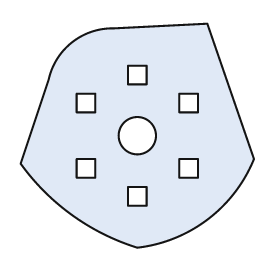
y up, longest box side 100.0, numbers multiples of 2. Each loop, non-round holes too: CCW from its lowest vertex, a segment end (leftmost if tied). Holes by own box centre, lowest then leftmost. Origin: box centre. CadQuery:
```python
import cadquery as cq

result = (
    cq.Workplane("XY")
    .moveTo(0.0, -48.0)
    .threePointArc((30.0, -36.0), (50.0, -10.0))
    .lineTo(30.0, 48.0)
    .lineTo(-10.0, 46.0)
    .threePointArc((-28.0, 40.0), (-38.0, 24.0))
    .lineTo(-50.0, -12.0)
    .threePointArc((-28.0, -34.0), (0.0, -48.0))
    .close()
    .moveTo(-4.0, -30.0)
    .lineTo(4.0, -30.0)
    .lineTo(4.0, -22.0)
    .lineTo(-4.0, -22.0)
    .close()
    .moveTo(-26.0, -18.0)
    .lineTo(-18.0, -18.0)
    .lineTo(-18.0, -10.0)
    .lineTo(-26.0, -10.0)
    .close()
    .moveTo(18.0, -18.0)
    .lineTo(26.0, -18.0)
    .lineTo(26.0, -10.0)
    .lineTo(18.0, -10.0)
    .close()
    .moveTo(0.0, 0.0)
    .circle(8.0)
    .moveTo(-26.0, 10.0)
    .lineTo(-18.0, 10.0)
    .lineTo(-18.0, 18.0)
    .lineTo(-26.0, 18.0)
    .close()
    .moveTo(18.0, 10.0)
    .lineTo(26.0, 10.0)
    .lineTo(26.0, 18.0)
    .lineTo(18.0, 18.0)
    .close()
    .moveTo(-4.0, 22.0)
    .lineTo(4.0, 22.0)
    .lineTo(4.0, 30.0)
    .lineTo(-4.0, 30.0)
    .close()
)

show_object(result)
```